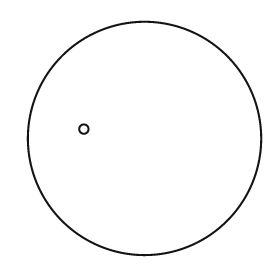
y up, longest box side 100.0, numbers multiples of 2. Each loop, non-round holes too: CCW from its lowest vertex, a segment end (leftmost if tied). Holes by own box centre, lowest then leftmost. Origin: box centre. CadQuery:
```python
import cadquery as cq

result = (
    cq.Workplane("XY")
    .moveTo(0.0, 0.0)
    .circle(50.0)
    .moveTo(-26.0, 4.0)
    .circle(2.0)
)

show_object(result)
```